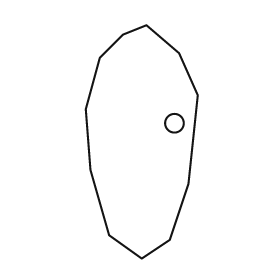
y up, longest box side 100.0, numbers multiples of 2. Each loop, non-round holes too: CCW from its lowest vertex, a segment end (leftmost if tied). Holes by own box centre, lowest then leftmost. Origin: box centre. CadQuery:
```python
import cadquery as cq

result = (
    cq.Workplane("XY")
    .moveTo(0.0, -50.0)
    .lineTo(12.0, -42.0)
    .lineTo(20.0, -18.0)
    .lineTo(24.0, 20.0)
    .lineTo(16.0, 38.0)
    .lineTo(2.0, 50.0)
    .lineTo(-8.0, 46.0)
    .lineTo(-18.0, 36.0)
    .lineTo(-24.0, 14.0)
    .lineTo(-22.0, -12.0)
    .lineTo(-14.0, -40.0)
    .close()
    .moveTo(14.0, 8.0)
    .circle(4.0)
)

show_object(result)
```